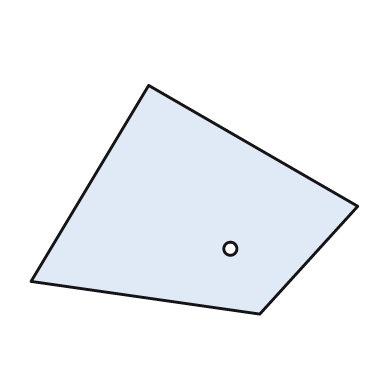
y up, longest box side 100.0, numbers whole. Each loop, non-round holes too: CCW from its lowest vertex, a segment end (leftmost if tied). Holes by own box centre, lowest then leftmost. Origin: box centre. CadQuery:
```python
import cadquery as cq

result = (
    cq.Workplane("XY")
    .moveTo(20.0, -35.0)
    .lineTo(50.0, -2.0)
    .lineTo(-14.0, 35.0)
    .lineTo(-50.0, -25.0)
    .close()
    .moveTo(11.0, -15.0)
    .circle(2.0)
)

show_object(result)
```